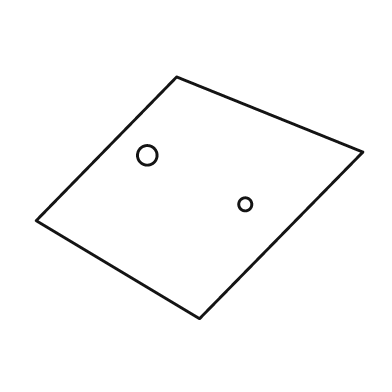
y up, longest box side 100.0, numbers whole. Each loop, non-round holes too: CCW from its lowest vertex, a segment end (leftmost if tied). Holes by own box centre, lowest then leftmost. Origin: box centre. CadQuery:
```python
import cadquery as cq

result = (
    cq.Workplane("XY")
    .moveTo(0.0, -37.0)
    .lineTo(50.0, 14.0)
    .lineTo(-7.0, 37.0)
    .lineTo(-50.0, -7.0)
    .close()
    .moveTo(14.0, -2.0)
    .circle(2.0)
    .moveTo(-16.0, 13.0)
    .circle(3.0)
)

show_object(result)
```